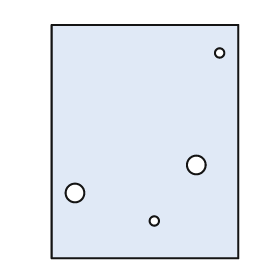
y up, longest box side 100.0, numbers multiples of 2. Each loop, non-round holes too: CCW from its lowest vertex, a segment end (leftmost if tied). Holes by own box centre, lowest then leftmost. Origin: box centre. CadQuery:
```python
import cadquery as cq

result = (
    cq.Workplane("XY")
    .moveTo(-40.0, -50.0)
    .lineTo(40.0, -50.0)
    .lineTo(40.0, 50.0)
    .lineTo(-40.0, 50.0)
    .close()
    .moveTo(4.0, -34.0)
    .circle(2.0)
    .moveTo(-30.0, -22.0)
    .circle(4.0)
    .moveTo(22.0, -10.0)
    .circle(4.0)
    .moveTo(32.0, 38.0)
    .circle(2.0)
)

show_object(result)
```